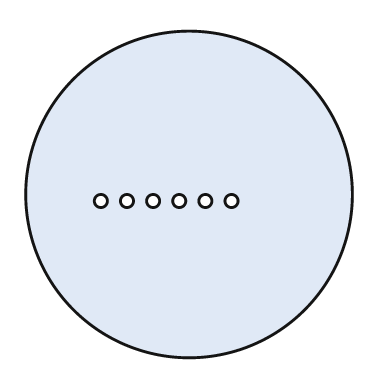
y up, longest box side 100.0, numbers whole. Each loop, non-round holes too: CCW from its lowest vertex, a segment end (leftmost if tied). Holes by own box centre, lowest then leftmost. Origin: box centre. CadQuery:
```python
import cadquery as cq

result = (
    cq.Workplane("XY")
    .moveTo(0.0, 0.0)
    .circle(50.0)
    .moveTo(-27.0, -2.0)
    .circle(2.0)
    .moveTo(-19.0, -2.0)
    .circle(2.0)
    .moveTo(-11.0, -2.0)
    .circle(2.0)
    .moveTo(-3.0, -2.0)
    .circle(2.0)
    .moveTo(5.0, -2.0)
    .circle(2.0)
    .moveTo(13.0, -2.0)
    .circle(2.0)
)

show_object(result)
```